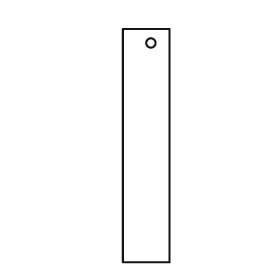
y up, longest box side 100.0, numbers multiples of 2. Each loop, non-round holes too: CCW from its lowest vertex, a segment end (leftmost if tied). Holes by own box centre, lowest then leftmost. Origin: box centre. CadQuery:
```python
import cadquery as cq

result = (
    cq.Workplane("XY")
    .moveTo(-10.0, -50.0)
    .lineTo(10.0, -50.0)
    .lineTo(10.0, 50.0)
    .lineTo(-10.0, 50.0)
    .close()
    .moveTo(2.0, 44.0)
    .circle(2.0)
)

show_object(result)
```